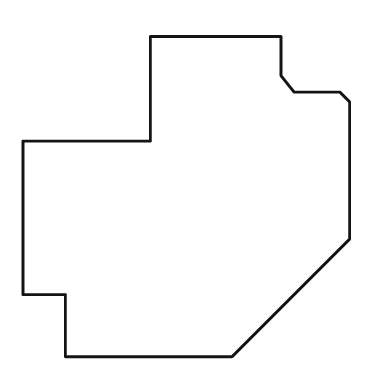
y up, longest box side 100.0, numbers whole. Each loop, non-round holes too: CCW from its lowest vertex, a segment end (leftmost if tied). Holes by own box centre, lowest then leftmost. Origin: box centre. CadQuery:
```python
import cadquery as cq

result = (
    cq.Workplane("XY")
    .moveTo(-37.0, -49.0)
    .lineTo(14.0, -49.0)
    .lineTo(50.0, -13.0)
    .lineTo(50.0, 29.0)
    .lineTo(47.0, 32.0)
    .lineTo(33.0, 32.0)
    .lineTo(29.0, 37.0)
    .lineTo(29.0, 49.0)
    .lineTo(-11.0, 49.0)
    .lineTo(-11.0, 17.0)
    .lineTo(-50.0, 17.0)
    .lineTo(-50.0, -30.0)
    .lineTo(-37.0, -30.0)
    .close()
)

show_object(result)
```